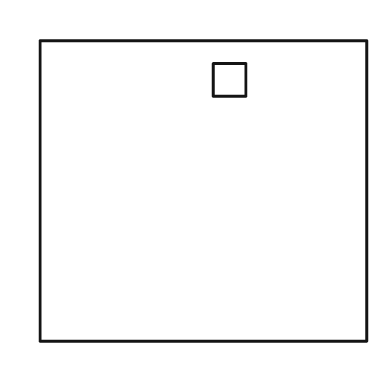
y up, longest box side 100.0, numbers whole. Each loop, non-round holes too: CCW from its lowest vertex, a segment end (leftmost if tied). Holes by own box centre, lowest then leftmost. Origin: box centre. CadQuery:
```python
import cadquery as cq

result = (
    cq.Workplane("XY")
    .moveTo(-50.0, -46.0)
    .lineTo(50.0, -46.0)
    .lineTo(50.0, 46.0)
    .lineTo(-50.0, 46.0)
    .close()
    .moveTo(3.0, 29.0)
    .lineTo(13.0, 29.0)
    .lineTo(13.0, 39.0)
    .lineTo(3.0, 39.0)
    .close()
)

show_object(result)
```